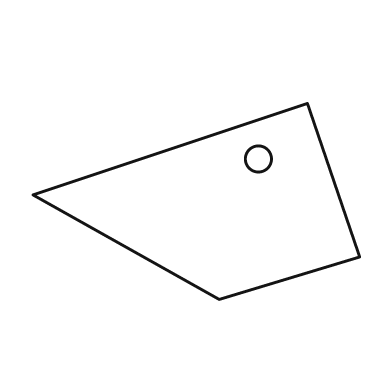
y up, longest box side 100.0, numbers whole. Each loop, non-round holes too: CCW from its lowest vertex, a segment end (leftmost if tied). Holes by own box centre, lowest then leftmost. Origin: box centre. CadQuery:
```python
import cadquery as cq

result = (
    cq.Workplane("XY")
    .moveTo(7.0, -30.0)
    .lineTo(50.0, -17.0)
    .lineTo(34.0, 30.0)
    .lineTo(-50.0, 2.0)
    .close()
    .moveTo(19.0, 13.0)
    .circle(4.0)
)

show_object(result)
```